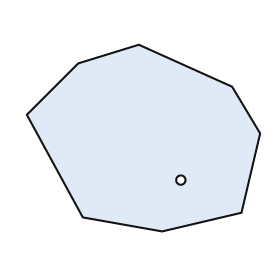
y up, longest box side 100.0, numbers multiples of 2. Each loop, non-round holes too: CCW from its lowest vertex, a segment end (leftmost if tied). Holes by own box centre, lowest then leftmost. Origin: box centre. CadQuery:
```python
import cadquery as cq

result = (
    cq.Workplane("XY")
    .moveTo(8.0, -40.0)
    .lineTo(42.0, -32.0)
    .lineTo(50.0, 2.0)
    .lineTo(38.0, 22.0)
    .lineTo(-2.0, 40.0)
    .lineTo(-28.0, 32.0)
    .lineTo(-50.0, 10.0)
    .lineTo(-26.0, -34.0)
    .close()
    .moveTo(16.0, -18.0)
    .circle(2.0)
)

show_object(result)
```